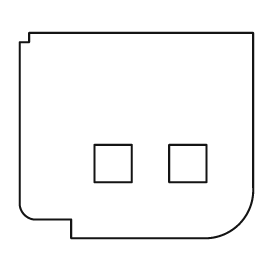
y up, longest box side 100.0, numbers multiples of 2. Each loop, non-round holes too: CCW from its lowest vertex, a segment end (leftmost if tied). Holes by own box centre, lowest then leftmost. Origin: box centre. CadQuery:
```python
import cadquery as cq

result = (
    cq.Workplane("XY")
    .moveTo(-28.0, -44.0)
    .lineTo(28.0, -44.0)
    .threePointArc((44.0, -38.0), (50.0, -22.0))
    .lineTo(50.0, 44.0)
    .lineTo(-46.0, 44.0)
    .lineTo(-46.0, 40.0)
    .lineTo(-50.0, 40.0)
    .lineTo(-50.0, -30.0)
    .threePointArc((-48.0, -34.0), (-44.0, -36.0))
    .lineTo(-28.0, -36.0)
    .close()
    .moveTo(-18.0, -20.0)
    .lineTo(-2.0, -20.0)
    .lineTo(-2.0, -4.0)
    .lineTo(-18.0, -4.0)
    .close()
    .moveTo(14.0, -20.0)
    .lineTo(30.0, -20.0)
    .lineTo(30.0, -4.0)
    .lineTo(14.0, -4.0)
    .close()
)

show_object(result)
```